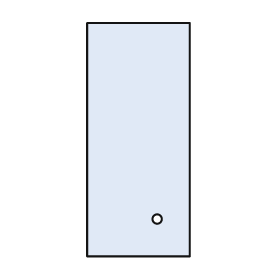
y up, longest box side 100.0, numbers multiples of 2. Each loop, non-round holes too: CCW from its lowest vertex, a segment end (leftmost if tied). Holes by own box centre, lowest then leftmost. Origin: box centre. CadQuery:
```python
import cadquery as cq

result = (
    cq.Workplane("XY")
    .moveTo(-22.0, -50.0)
    .lineTo(22.0, -50.0)
    .lineTo(22.0, 50.0)
    .lineTo(-22.0, 50.0)
    .close()
    .moveTo(8.0, -34.0)
    .circle(2.0)
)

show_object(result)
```